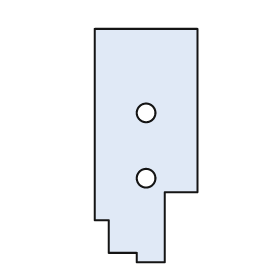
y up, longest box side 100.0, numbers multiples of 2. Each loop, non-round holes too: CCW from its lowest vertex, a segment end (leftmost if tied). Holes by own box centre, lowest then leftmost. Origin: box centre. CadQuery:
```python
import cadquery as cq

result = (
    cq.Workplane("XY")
    .moveTo(-4.0, -50.0)
    .lineTo(8.0, -50.0)
    .lineTo(8.0, -20.0)
    .lineTo(22.0, -20.0)
    .lineTo(22.0, 50.0)
    .lineTo(-22.0, 50.0)
    .lineTo(-22.0, -32.0)
    .lineTo(-16.0, -32.0)
    .lineTo(-16.0, -46.0)
    .lineTo(-4.0, -46.0)
    .close()
    .moveTo(0.0, -14.0)
    .circle(4.0)
    .moveTo(0.0, 14.0)
    .circle(4.0)
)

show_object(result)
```